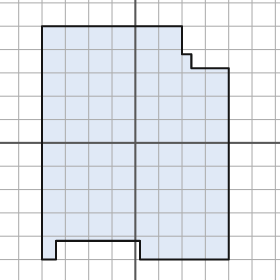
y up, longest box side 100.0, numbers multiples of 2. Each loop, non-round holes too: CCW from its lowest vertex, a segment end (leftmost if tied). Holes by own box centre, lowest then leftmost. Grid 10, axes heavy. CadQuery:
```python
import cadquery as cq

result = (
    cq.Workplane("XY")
    .moveTo(-40.0, -50.0)
    .lineTo(-34.0, -50.0)
    .lineTo(-34.0, -42.0)
    .lineTo(2.0, -42.0)
    .lineTo(2.0, -50.0)
    .lineTo(40.0, -50.0)
    .lineTo(40.0, 32.0)
    .lineTo(24.0, 32.0)
    .lineTo(24.0, 38.0)
    .lineTo(20.0, 38.0)
    .lineTo(20.0, 50.0)
    .lineTo(-40.0, 50.0)
    .close()
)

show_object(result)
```